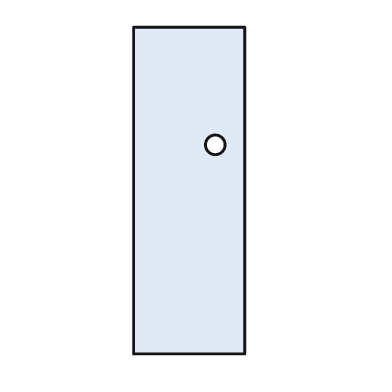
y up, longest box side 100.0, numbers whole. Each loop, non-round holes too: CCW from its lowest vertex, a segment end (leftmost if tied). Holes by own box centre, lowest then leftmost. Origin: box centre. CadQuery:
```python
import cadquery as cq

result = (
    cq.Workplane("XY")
    .moveTo(-17.0, -50.0)
    .lineTo(17.0, -50.0)
    .lineTo(17.0, 50.0)
    .lineTo(-17.0, 50.0)
    .close()
    .moveTo(8.0, 14.0)
    .circle(3.0)
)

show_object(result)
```